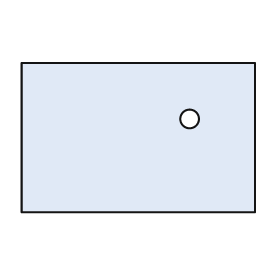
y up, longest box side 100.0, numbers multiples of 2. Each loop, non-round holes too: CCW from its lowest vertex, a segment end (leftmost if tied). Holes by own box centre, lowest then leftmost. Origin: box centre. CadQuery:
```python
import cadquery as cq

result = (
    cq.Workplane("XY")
    .moveTo(-50.0, -32.0)
    .lineTo(50.0, -32.0)
    .lineTo(50.0, 32.0)
    .lineTo(-50.0, 32.0)
    .close()
    .moveTo(22.0, 8.0)
    .circle(4.0)
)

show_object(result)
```